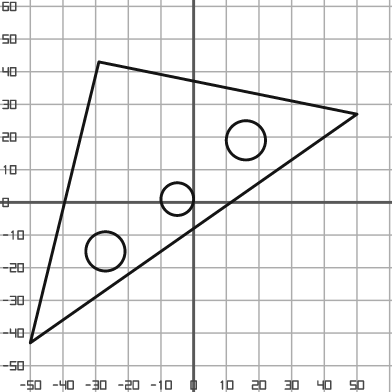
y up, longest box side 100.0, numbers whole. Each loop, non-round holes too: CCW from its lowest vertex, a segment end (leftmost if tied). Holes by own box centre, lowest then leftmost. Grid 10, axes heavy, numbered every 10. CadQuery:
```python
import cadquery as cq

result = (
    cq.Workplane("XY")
    .moveTo(-50.0, -43.0)
    .lineTo(50.0, 27.0)
    .lineTo(-29.0, 43.0)
    .close()
    .moveTo(-27.0, -15.0)
    .circle(6.0)
    .moveTo(-5.0, 1.0)
    .circle(5.0)
    .moveTo(16.0, 19.0)
    .circle(6.0)
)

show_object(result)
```